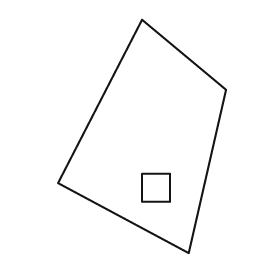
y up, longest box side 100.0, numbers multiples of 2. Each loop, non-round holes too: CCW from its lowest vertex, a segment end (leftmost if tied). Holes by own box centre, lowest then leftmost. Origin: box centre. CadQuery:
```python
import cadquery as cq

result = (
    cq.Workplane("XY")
    .moveTo(20.0, -50.0)
    .lineTo(36.0, 20.0)
    .lineTo(0.0, 50.0)
    .lineTo(-36.0, -20.0)
    .close()
    .moveTo(0.0, -28.0)
    .lineTo(12.0, -28.0)
    .lineTo(12.0, -16.0)
    .lineTo(0.0, -16.0)
    .close()
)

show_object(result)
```